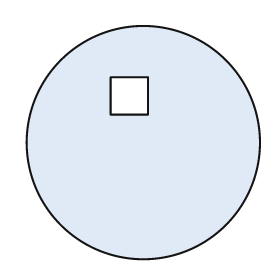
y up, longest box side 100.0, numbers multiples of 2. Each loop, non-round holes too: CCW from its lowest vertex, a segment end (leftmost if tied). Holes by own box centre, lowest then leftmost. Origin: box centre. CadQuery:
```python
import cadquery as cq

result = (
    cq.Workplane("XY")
    .moveTo(0.0, 0.0)
    .circle(50.0)
    .moveTo(-14.0, 12.0)
    .lineTo(2.0, 12.0)
    .lineTo(2.0, 28.0)
    .lineTo(-14.0, 28.0)
    .close()
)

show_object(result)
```